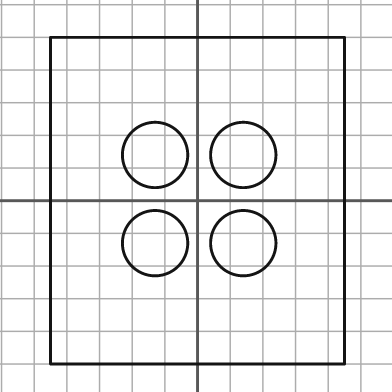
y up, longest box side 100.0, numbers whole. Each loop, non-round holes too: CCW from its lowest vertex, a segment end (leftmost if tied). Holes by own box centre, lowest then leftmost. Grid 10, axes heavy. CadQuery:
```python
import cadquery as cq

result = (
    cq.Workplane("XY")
    .moveTo(-45.0, -50.0)
    .lineTo(45.0, -50.0)
    .lineTo(45.0, 50.0)
    .lineTo(-45.0, 50.0)
    .close()
    .moveTo(-13.0, -13.0)
    .circle(10.0)
    .moveTo(14.0, -13.0)
    .circle(10.0)
    .moveTo(-13.0, 14.0)
    .circle(10.0)
    .moveTo(14.0, 14.0)
    .circle(10.0)
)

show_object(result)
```